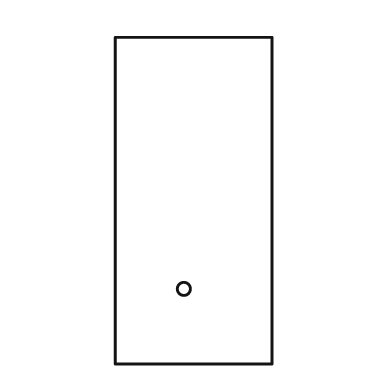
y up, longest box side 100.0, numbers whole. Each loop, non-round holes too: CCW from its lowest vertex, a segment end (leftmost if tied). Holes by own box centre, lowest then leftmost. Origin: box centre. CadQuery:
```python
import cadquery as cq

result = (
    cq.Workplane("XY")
    .moveTo(-24.0, -50.0)
    .lineTo(24.0, -50.0)
    .lineTo(24.0, 50.0)
    .lineTo(-24.0, 50.0)
    .close()
    .moveTo(-3.0, -27.0)
    .circle(2.0)
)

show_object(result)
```